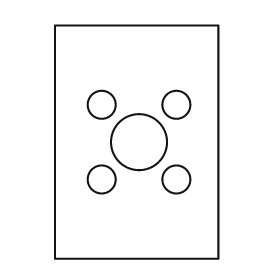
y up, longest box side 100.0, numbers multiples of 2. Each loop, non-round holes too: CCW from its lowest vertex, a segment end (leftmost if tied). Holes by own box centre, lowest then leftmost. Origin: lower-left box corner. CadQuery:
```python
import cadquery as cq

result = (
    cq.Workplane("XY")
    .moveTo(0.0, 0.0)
    .lineTo(70.0, 0.0)
    .lineTo(70.0, 100.0)
    .lineTo(0.0, 100.0)
    .close()
    .moveTo(20.0, 34.0)
    .circle(6.0)
    .moveTo(52.0, 34.0)
    .circle(6.0)
    .moveTo(36.0, 50.0)
    .circle(12.0)
    .moveTo(20.0, 66.0)
    .circle(6.0)
    .moveTo(52.0, 66.0)
    .circle(6.0)
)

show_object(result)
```